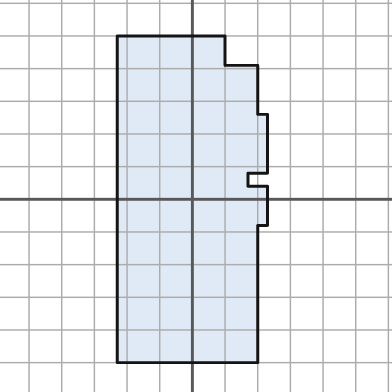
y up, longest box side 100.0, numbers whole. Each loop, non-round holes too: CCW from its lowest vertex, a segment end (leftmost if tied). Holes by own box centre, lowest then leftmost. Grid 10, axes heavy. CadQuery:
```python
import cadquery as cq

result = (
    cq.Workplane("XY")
    .moveTo(-23.0, -50.0)
    .lineTo(20.0, -50.0)
    .lineTo(20.0, -8.0)
    .lineTo(23.0, -8.0)
    .lineTo(23.0, 4.0)
    .lineTo(17.0, 4.0)
    .lineTo(17.0, 8.0)
    .lineTo(23.0, 8.0)
    .lineTo(23.0, 26.0)
    .lineTo(20.0, 26.0)
    .lineTo(20.0, 41.0)
    .lineTo(10.0, 41.0)
    .lineTo(10.0, 50.0)
    .lineTo(-23.0, 50.0)
    .close()
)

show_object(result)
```